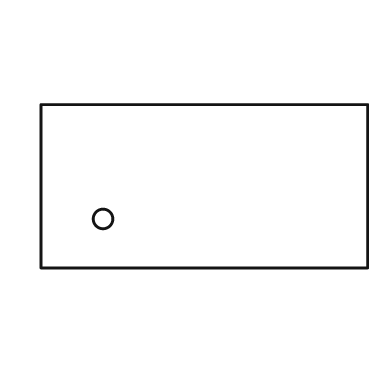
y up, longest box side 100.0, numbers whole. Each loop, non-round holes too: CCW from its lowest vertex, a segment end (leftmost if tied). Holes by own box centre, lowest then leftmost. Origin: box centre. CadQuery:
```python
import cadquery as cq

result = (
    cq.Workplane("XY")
    .moveTo(-50.0, -25.0)
    .lineTo(50.0, -25.0)
    .lineTo(50.0, 25.0)
    .lineTo(-50.0, 25.0)
    .close()
    .moveTo(-31.0, -10.0)
    .circle(3.0)
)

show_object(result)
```